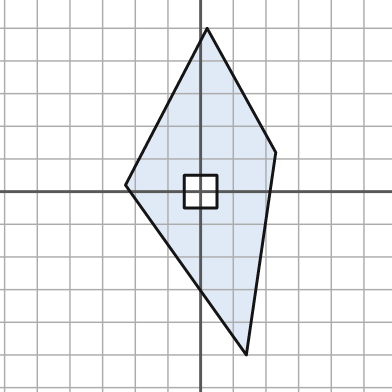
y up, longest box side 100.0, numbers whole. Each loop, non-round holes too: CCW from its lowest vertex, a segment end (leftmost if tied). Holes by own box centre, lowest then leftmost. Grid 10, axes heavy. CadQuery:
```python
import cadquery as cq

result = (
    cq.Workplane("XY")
    .moveTo(14.0, -50.0)
    .lineTo(23.0, 12.0)
    .lineTo(2.0, 50.0)
    .lineTo(-23.0, 2.0)
    .close()
    .moveTo(-5.0, -5.0)
    .lineTo(5.0, -5.0)
    .lineTo(5.0, 5.0)
    .lineTo(-5.0, 5.0)
    .close()
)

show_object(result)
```